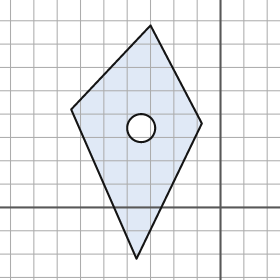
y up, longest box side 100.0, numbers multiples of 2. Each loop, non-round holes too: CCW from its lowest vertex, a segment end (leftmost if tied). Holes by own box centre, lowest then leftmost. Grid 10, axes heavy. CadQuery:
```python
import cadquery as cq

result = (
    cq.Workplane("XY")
    .moveTo(-36.0, -22.0)
    .lineTo(-8.0, 36.0)
    .lineTo(-30.0, 78.0)
    .lineTo(-64.0, 42.0)
    .close()
    .moveTo(-34.0, 34.0)
    .circle(6.0)
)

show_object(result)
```